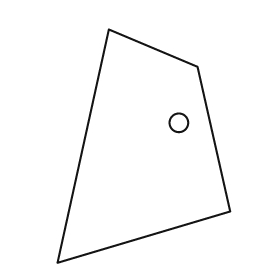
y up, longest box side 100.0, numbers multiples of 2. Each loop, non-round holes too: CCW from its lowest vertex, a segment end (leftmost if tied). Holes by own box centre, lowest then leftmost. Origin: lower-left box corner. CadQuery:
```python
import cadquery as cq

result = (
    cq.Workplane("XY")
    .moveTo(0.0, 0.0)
    .lineTo(74.0, 22.0)
    .lineTo(60.0, 84.0)
    .lineTo(22.0, 100.0)
    .close()
    .moveTo(52.0, 60.0)
    .circle(4.0)
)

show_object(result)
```